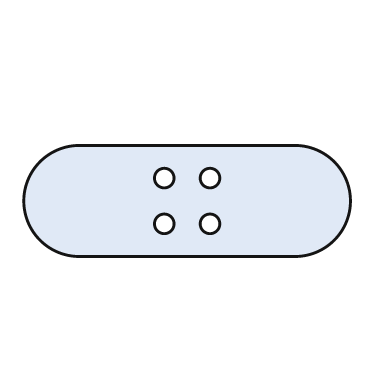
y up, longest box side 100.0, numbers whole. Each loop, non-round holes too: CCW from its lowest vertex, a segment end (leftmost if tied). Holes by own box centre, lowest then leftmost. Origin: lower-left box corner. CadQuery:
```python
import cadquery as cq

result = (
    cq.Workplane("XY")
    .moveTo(17.0, 0.0)
    .lineTo(83.0, 0.0)
    .threePointArc((100.0, 17.0), (83.0, 34.0))
    .lineTo(17.0, 34.0)
    .threePointArc((0.0, 17.0), (17.0, 0.0))
    .close()
    .moveTo(43.0, 10.0)
    .circle(3.0)
    .moveTo(57.0, 10.0)
    .circle(3.0)
    .moveTo(43.0, 24.0)
    .circle(3.0)
    .moveTo(57.0, 24.0)
    .circle(3.0)
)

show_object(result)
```